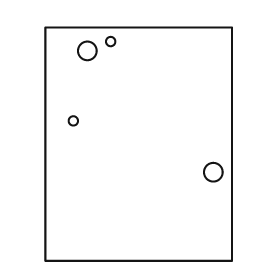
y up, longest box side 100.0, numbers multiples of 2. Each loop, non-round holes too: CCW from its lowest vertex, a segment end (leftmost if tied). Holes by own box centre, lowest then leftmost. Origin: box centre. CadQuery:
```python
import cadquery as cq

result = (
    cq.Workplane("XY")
    .moveTo(-40.0, -50.0)
    .lineTo(40.0, -50.0)
    .lineTo(40.0, 50.0)
    .lineTo(-40.0, 50.0)
    .close()
    .moveTo(32.0, -12.0)
    .circle(4.0)
    .moveTo(-28.0, 10.0)
    .circle(2.0)
    .moveTo(-22.0, 40.0)
    .circle(4.0)
    .moveTo(-12.0, 44.0)
    .circle(2.0)
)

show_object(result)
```